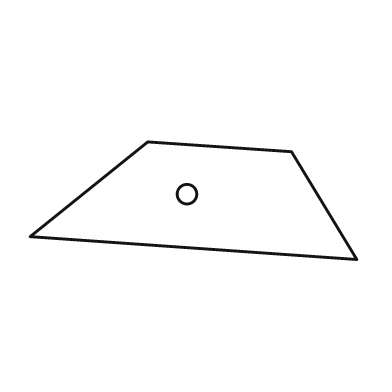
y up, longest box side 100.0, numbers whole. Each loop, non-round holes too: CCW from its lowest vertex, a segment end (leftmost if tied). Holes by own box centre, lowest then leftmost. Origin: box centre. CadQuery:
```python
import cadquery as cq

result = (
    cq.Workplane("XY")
    .moveTo(50.0, -18.0)
    .lineTo(30.0, 15.0)
    .lineTo(-14.0, 18.0)
    .lineTo(-50.0, -11.0)
    .close()
    .moveTo(-2.0, 2.0)
    .circle(3.0)
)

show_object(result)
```